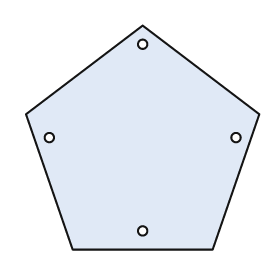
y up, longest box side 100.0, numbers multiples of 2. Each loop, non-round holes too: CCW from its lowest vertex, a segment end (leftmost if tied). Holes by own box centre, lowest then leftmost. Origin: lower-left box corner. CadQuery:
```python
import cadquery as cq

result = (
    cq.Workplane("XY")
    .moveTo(20.0, 0.0)
    .lineTo(80.0, 0.0)
    .lineTo(100.0, 58.0)
    .lineTo(50.0, 96.0)
    .lineTo(0.0, 58.0)
    .close()
    .moveTo(50.0, 8.0)
    .circle(2.0)
    .moveTo(10.0, 48.0)
    .circle(2.0)
    .moveTo(90.0, 48.0)
    .circle(2.0)
    .moveTo(50.0, 88.0)
    .circle(2.0)
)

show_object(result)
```